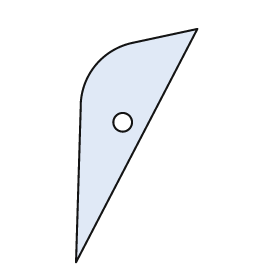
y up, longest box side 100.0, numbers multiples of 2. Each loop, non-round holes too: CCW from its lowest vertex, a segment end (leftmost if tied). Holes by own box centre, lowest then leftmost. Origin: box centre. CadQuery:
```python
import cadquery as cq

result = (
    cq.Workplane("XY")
    .moveTo(-26.0, -50.0)
    .lineTo(26.0, 50.0)
    .lineTo(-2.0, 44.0)
    .threePointArc((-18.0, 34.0), (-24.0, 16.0))
    .close()
    .moveTo(-6.0, 10.0)
    .circle(4.0)
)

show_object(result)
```